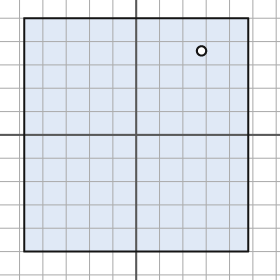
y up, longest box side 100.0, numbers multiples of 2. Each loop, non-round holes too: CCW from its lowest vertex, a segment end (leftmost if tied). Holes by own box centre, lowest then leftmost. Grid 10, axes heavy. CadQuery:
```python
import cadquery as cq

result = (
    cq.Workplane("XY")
    .moveTo(-48.0, -50.0)
    .lineTo(48.0, -50.0)
    .lineTo(48.0, 50.0)
    .lineTo(-48.0, 50.0)
    .close()
    .moveTo(28.0, 36.0)
    .circle(2.0)
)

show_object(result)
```